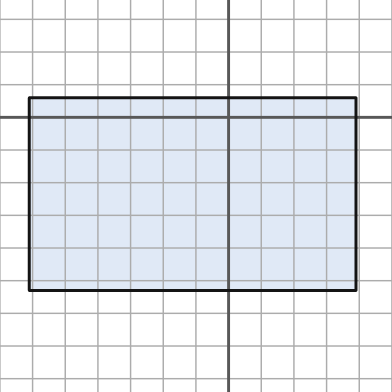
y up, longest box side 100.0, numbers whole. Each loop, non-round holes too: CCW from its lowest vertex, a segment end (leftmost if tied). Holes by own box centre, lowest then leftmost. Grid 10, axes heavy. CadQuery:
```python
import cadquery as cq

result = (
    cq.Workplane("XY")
    .moveTo(-61.0, -53.0)
    .lineTo(39.0, -53.0)
    .lineTo(39.0, 6.0)
    .lineTo(-61.0, 6.0)
    .close()
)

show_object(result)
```